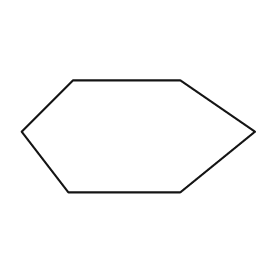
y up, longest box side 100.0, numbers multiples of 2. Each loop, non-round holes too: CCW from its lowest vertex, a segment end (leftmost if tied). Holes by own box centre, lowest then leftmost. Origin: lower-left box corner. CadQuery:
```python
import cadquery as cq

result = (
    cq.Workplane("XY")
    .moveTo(20.0, 0.0)
    .lineTo(68.0, 0.0)
    .lineTo(100.0, 26.0)
    .lineTo(68.0, 48.0)
    .lineTo(22.0, 48.0)
    .lineTo(0.0, 26.0)
    .close()
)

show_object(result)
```